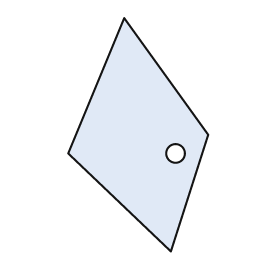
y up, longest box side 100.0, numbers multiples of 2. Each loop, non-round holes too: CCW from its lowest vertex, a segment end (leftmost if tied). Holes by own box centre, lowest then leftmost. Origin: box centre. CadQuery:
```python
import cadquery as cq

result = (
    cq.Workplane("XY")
    .moveTo(14.0, -50.0)
    .lineTo(30.0, 0.0)
    .lineTo(-6.0, 50.0)
    .lineTo(-30.0, -8.0)
    .close()
    .moveTo(16.0, -8.0)
    .circle(4.0)
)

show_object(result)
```